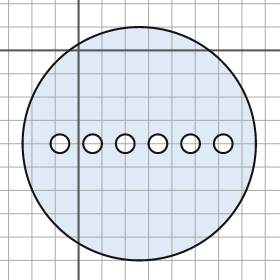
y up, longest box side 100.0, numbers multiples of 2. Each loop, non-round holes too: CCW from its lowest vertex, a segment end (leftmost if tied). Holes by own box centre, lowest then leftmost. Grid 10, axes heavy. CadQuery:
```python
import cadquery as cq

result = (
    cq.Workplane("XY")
    .moveTo(26.0, -40.0)
    .circle(50.0)
    .moveTo(-8.0, -40.0)
    .circle(4.0)
    .moveTo(6.0, -40.0)
    .circle(4.0)
    .moveTo(20.0, -40.0)
    .circle(4.0)
    .moveTo(34.0, -40.0)
    .circle(4.0)
    .moveTo(48.0, -40.0)
    .circle(4.0)
    .moveTo(62.0, -40.0)
    .circle(4.0)
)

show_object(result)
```